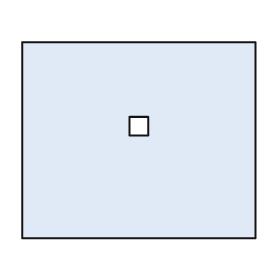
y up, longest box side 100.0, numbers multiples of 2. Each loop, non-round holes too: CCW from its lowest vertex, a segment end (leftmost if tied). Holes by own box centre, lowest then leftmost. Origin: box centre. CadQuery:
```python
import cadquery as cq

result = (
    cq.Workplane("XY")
    .moveTo(-50.0, -42.0)
    .lineTo(50.0, -42.0)
    .lineTo(50.0, 42.0)
    .lineTo(-50.0, 42.0)
    .close()
    .moveTo(-4.0, 2.0)
    .lineTo(4.0, 2.0)
    .lineTo(4.0, 10.0)
    .lineTo(-4.0, 10.0)
    .close()
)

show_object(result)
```